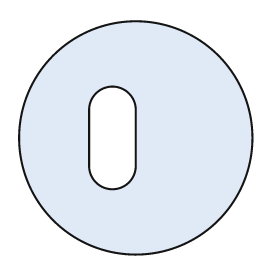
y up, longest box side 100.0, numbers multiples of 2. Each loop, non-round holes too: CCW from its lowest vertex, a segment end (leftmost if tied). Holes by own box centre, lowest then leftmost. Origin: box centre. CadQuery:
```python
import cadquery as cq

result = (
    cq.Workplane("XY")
    .moveTo(0.0, 0.0)
    .circle(50.0)
    .moveTo(-20.0, -12.0)
    .threePointArc((-10.0, -22.0), (0.0, -12.0))
    .lineTo(0.0, 12.0)
    .threePointArc((-10.0, 22.0), (-20.0, 12.0))
    .close()
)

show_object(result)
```